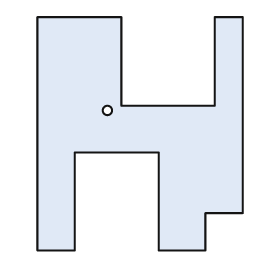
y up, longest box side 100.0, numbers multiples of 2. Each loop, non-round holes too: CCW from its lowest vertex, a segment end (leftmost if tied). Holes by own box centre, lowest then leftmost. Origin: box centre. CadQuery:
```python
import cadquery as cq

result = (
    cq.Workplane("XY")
    .moveTo(-44.0, -50.0)
    .lineTo(-28.0, -50.0)
    .lineTo(-28.0, -8.0)
    .lineTo(8.0, -8.0)
    .lineTo(8.0, -50.0)
    .lineTo(28.0, -50.0)
    .lineTo(28.0, -34.0)
    .lineTo(44.0, -34.0)
    .lineTo(44.0, 50.0)
    .lineTo(32.0, 50.0)
    .lineTo(32.0, 12.0)
    .lineTo(-8.0, 12.0)
    .lineTo(-8.0, 50.0)
    .lineTo(-44.0, 50.0)
    .close()
    .moveTo(-14.0, 10.0)
    .circle(2.0)
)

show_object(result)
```